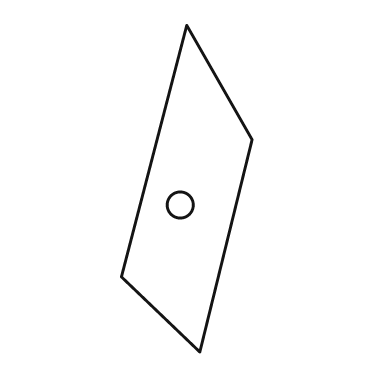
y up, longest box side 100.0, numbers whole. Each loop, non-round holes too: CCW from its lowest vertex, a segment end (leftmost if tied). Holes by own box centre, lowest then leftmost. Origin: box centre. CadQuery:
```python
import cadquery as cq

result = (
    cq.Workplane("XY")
    .moveTo(4.0, -50.0)
    .lineTo(20.0, 15.0)
    .lineTo(0.0, 50.0)
    .lineTo(-20.0, -27.0)
    .close()
    .moveTo(-2.0, -5.0)
    .circle(4.0)
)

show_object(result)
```